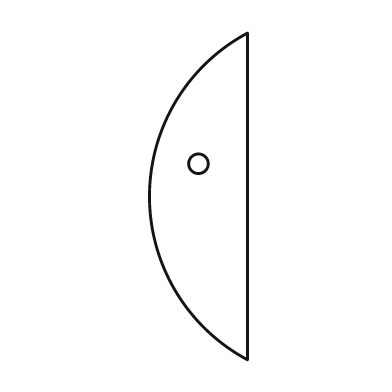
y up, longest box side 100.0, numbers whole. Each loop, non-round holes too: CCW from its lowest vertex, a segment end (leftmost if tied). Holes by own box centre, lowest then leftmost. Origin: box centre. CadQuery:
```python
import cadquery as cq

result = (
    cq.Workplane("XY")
    .moveTo(15.0, -50.0)
    .lineTo(15.0, 50.0)
    .threePointArc((-15.0, 0.0), (15.0, -50.0))
    .close()
    .moveTo(0.0, 10.0)
    .circle(3.0)
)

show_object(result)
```